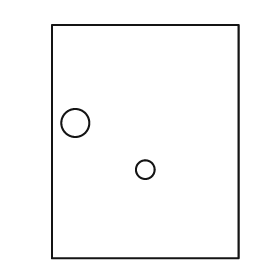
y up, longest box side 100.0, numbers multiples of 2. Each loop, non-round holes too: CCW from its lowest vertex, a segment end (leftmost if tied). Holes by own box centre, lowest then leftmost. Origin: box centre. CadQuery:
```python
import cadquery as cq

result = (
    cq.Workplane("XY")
    .moveTo(-40.0, -50.0)
    .lineTo(40.0, -50.0)
    .lineTo(40.0, 50.0)
    .lineTo(-40.0, 50.0)
    .close()
    .moveTo(0.0, -12.0)
    .circle(4.0)
    .moveTo(-30.0, 8.0)
    .circle(6.0)
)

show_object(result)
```